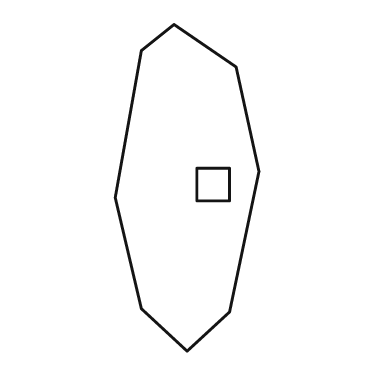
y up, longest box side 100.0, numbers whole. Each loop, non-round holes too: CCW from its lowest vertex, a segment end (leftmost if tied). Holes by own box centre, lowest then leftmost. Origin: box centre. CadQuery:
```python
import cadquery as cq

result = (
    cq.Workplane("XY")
    .moveTo(0.0, -50.0)
    .lineTo(13.0, -38.0)
    .lineTo(22.0, 5.0)
    .lineTo(15.0, 37.0)
    .lineTo(-4.0, 50.0)
    .lineTo(-14.0, 42.0)
    .lineTo(-22.0, -3.0)
    .lineTo(-14.0, -37.0)
    .close()
    .moveTo(3.0, -4.0)
    .lineTo(13.0, -4.0)
    .lineTo(13.0, 6.0)
    .lineTo(3.0, 6.0)
    .close()
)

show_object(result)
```